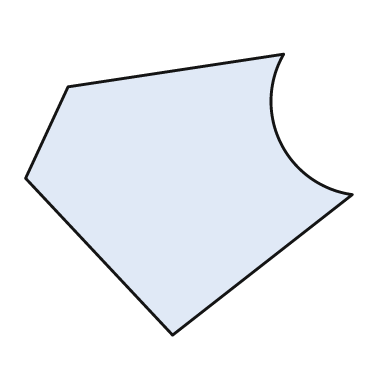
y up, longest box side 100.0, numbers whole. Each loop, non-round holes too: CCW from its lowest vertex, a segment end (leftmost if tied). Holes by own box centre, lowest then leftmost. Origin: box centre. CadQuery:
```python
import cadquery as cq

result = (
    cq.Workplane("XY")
    .moveTo(-5.0, -43.0)
    .lineTo(50.0, 0.0)
    .threePointArc((28.0, 16.0), (29.0, 43.0))
    .lineTo(-37.0, 33.0)
    .lineTo(-50.0, 5.0)
    .close()
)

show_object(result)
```